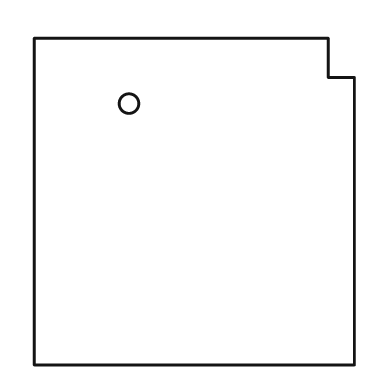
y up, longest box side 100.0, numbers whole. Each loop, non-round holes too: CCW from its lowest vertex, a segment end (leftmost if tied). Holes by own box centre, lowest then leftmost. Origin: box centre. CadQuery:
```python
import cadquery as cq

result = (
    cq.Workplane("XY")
    .moveTo(-49.0, -50.0)
    .lineTo(49.0, -50.0)
    .lineTo(49.0, 38.0)
    .lineTo(41.0, 38.0)
    .lineTo(41.0, 50.0)
    .lineTo(-49.0, 50.0)
    .close()
    .moveTo(-20.0, 30.0)
    .circle(3.0)
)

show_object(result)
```